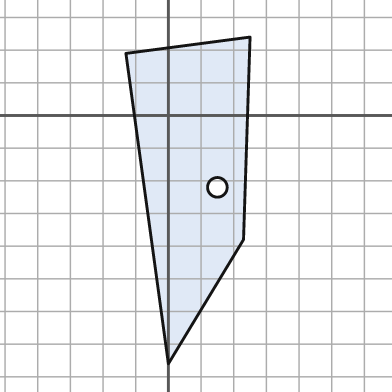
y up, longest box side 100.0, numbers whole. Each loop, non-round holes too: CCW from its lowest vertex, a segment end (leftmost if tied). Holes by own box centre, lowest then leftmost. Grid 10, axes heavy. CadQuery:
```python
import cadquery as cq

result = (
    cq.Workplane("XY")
    .moveTo(0.0, -76.0)
    .lineTo(23.0, -38.0)
    .lineTo(25.0, 24.0)
    .lineTo(-13.0, 19.0)
    .close()
    .moveTo(15.0, -22.0)
    .circle(3.0)
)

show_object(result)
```